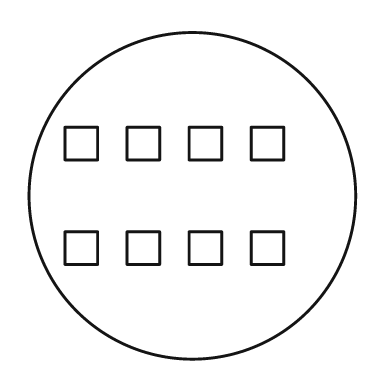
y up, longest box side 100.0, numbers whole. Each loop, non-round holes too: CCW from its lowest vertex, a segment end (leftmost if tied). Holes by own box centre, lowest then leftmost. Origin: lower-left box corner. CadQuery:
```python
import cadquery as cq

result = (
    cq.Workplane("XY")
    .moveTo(50.0, 50.0)
    .circle(50.0)
    .moveTo(11.0, 29.0)
    .lineTo(21.0, 29.0)
    .lineTo(21.0, 39.0)
    .lineTo(11.0, 39.0)
    .close()
    .moveTo(30.0, 29.0)
    .lineTo(40.0, 29.0)
    .lineTo(40.0, 39.0)
    .lineTo(30.0, 39.0)
    .close()
    .moveTo(49.0, 29.0)
    .lineTo(59.0, 29.0)
    .lineTo(59.0, 39.0)
    .lineTo(49.0, 39.0)
    .close()
    .moveTo(68.0, 29.0)
    .lineTo(78.0, 29.0)
    .lineTo(78.0, 39.0)
    .lineTo(68.0, 39.0)
    .close()
    .moveTo(11.0, 61.0)
    .lineTo(21.0, 61.0)
    .lineTo(21.0, 71.0)
    .lineTo(11.0, 71.0)
    .close()
    .moveTo(30.0, 61.0)
    .lineTo(40.0, 61.0)
    .lineTo(40.0, 71.0)
    .lineTo(30.0, 71.0)
    .close()
    .moveTo(49.0, 61.0)
    .lineTo(59.0, 61.0)
    .lineTo(59.0, 71.0)
    .lineTo(49.0, 71.0)
    .close()
    .moveTo(68.0, 61.0)
    .lineTo(78.0, 61.0)
    .lineTo(78.0, 71.0)
    .lineTo(68.0, 71.0)
    .close()
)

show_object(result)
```